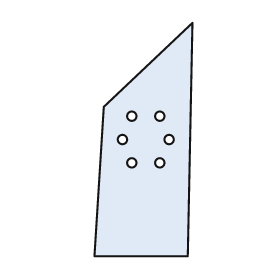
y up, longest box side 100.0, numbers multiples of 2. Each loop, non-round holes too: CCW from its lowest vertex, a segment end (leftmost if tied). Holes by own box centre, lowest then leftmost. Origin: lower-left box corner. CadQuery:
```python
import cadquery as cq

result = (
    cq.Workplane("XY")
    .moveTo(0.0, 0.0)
    .lineTo(40.0, 0.0)
    .lineTo(42.0, 100.0)
    .lineTo(4.0, 64.0)
    .close()
    .moveTo(16.0, 40.0)
    .circle(2.0)
    .moveTo(28.0, 40.0)
    .circle(2.0)
    .moveTo(12.0, 50.0)
    .circle(2.0)
    .moveTo(32.0, 50.0)
    .circle(2.0)
    .moveTo(16.0, 60.0)
    .circle(2.0)
    .moveTo(28.0, 60.0)
    .circle(2.0)
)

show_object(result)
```